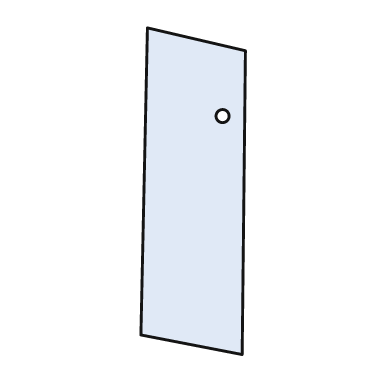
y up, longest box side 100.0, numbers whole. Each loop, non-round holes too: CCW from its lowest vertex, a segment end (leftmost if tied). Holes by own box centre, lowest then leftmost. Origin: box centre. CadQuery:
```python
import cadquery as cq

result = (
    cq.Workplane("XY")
    .moveTo(15.0, -50.0)
    .lineTo(16.0, 43.0)
    .lineTo(-14.0, 50.0)
    .lineTo(-16.0, -44.0)
    .close()
    .moveTo(9.0, 23.0)
    .circle(2.0)
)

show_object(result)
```